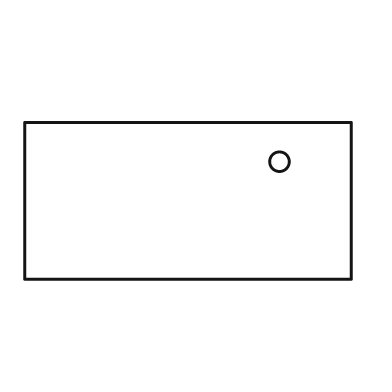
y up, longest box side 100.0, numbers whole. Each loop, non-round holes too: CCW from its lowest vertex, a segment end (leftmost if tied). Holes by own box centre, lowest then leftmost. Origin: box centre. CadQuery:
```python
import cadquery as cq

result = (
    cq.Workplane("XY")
    .moveTo(-50.0, -24.0)
    .lineTo(50.0, -24.0)
    .lineTo(50.0, 24.0)
    .lineTo(-50.0, 24.0)
    .close()
    .moveTo(28.0, 12.0)
    .circle(3.0)
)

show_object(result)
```